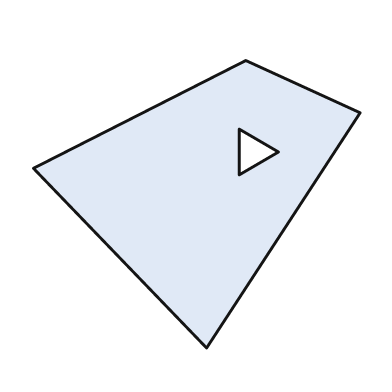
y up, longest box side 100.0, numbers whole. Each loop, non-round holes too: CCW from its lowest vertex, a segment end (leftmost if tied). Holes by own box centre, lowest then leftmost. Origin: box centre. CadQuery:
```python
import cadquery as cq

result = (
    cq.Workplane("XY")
    .moveTo(3.0, -44.0)
    .lineTo(50.0, 28.0)
    .lineTo(15.0, 44.0)
    .lineTo(-50.0, 11.0)
    .close()
    .moveTo(13.0, 9.0)
    .lineTo(25.0, 16.0)
    .lineTo(13.0, 23.0)
    .close()
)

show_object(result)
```